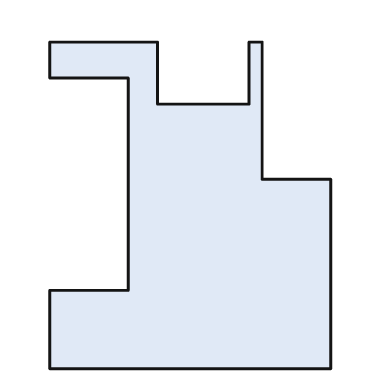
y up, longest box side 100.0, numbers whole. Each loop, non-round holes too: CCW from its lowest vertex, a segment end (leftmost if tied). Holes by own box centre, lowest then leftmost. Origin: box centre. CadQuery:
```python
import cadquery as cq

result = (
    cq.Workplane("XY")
    .moveTo(-43.0, -50.0)
    .lineTo(43.0, -50.0)
    .lineTo(43.0, 8.0)
    .lineTo(22.0, 8.0)
    .lineTo(22.0, 50.0)
    .lineTo(18.0, 50.0)
    .lineTo(18.0, 31.0)
    .lineTo(-10.0, 31.0)
    .lineTo(-10.0, 50.0)
    .lineTo(-43.0, 50.0)
    .lineTo(-43.0, 39.0)
    .lineTo(-19.0, 39.0)
    .lineTo(-19.0, -26.0)
    .lineTo(-43.0, -26.0)
    .close()
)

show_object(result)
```